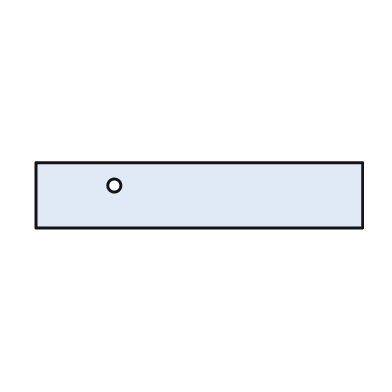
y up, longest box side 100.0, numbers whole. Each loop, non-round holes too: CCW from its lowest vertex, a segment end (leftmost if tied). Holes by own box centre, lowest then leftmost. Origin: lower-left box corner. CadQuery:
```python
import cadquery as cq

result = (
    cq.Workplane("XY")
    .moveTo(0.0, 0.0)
    .lineTo(100.0, 0.0)
    .lineTo(100.0, 20.0)
    .lineTo(0.0, 20.0)
    .close()
    .moveTo(24.0, 13.0)
    .circle(2.0)
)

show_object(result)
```